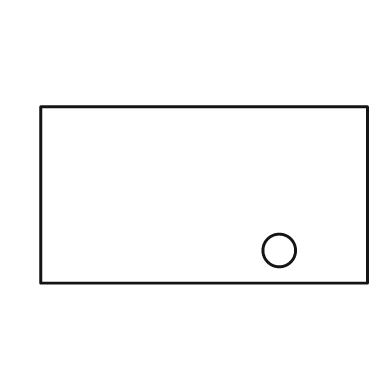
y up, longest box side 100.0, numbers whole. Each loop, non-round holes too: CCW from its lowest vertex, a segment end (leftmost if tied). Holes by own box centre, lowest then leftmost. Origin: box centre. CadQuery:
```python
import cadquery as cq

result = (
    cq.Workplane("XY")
    .moveTo(-50.0, -27.0)
    .lineTo(50.0, -27.0)
    .lineTo(50.0, 27.0)
    .lineTo(-50.0, 27.0)
    .close()
    .moveTo(23.0, -17.0)
    .circle(5.0)
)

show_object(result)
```